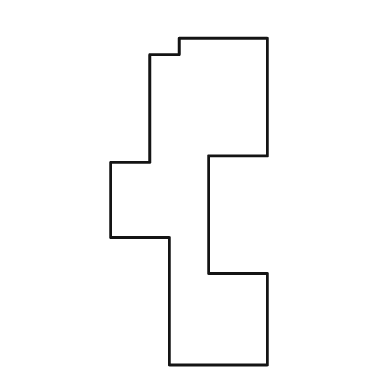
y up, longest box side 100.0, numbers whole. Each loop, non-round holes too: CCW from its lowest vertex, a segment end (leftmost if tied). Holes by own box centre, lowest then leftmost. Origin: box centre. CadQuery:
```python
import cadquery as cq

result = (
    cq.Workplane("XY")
    .moveTo(-6.0, -50.0)
    .lineTo(24.0, -50.0)
    .lineTo(24.0, -22.0)
    .lineTo(6.0, -22.0)
    .lineTo(6.0, 14.0)
    .lineTo(24.0, 14.0)
    .lineTo(24.0, 50.0)
    .lineTo(-3.0, 50.0)
    .lineTo(-3.0, 45.0)
    .lineTo(-12.0, 45.0)
    .lineTo(-12.0, 12.0)
    .lineTo(-24.0, 12.0)
    .lineTo(-24.0, -11.0)
    .lineTo(-6.0, -11.0)
    .close()
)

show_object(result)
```